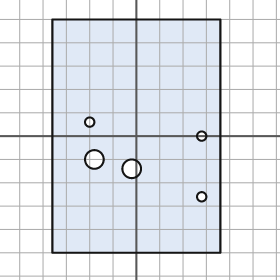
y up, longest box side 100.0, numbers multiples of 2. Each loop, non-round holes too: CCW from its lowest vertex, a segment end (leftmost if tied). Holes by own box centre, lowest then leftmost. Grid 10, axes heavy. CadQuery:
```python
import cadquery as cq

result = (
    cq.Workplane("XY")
    .moveTo(-36.0, -50.0)
    .lineTo(36.0, -50.0)
    .lineTo(36.0, 50.0)
    .lineTo(-36.0, 50.0)
    .close()
    .moveTo(28.0, -26.0)
    .circle(2.0)
    .moveTo(-2.0, -14.0)
    .circle(4.0)
    .moveTo(-18.0, -10.0)
    .circle(4.0)
    .moveTo(28.0, 0.0)
    .circle(2.0)
    .moveTo(-20.0, 6.0)
    .circle(2.0)
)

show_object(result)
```